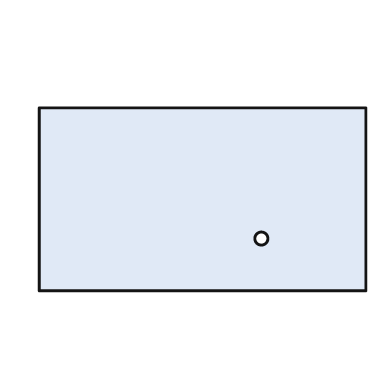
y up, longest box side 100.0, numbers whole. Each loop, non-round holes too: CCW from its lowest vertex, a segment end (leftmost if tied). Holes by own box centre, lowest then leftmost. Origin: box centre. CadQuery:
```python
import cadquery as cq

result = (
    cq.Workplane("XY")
    .moveTo(-50.0, -28.0)
    .lineTo(50.0, -28.0)
    .lineTo(50.0, 28.0)
    .lineTo(-50.0, 28.0)
    .close()
    .moveTo(18.0, -12.0)
    .circle(2.0)
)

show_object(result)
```